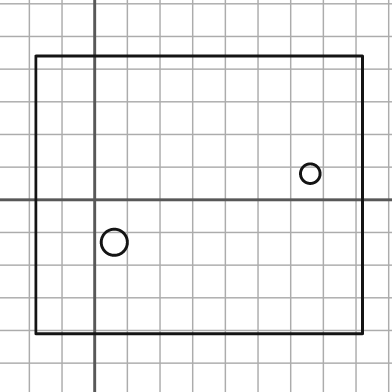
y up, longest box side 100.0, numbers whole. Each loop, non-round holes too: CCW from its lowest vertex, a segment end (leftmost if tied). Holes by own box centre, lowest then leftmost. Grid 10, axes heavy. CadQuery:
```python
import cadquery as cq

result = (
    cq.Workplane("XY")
    .moveTo(-18.0, -41.0)
    .lineTo(82.0, -41.0)
    .lineTo(82.0, 44.0)
    .lineTo(-18.0, 44.0)
    .close()
    .moveTo(6.0, -13.0)
    .circle(4.0)
    .moveTo(66.0, 8.0)
    .circle(3.0)
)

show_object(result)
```